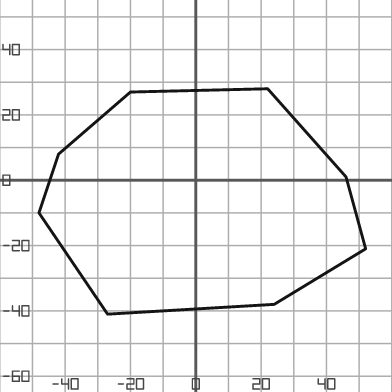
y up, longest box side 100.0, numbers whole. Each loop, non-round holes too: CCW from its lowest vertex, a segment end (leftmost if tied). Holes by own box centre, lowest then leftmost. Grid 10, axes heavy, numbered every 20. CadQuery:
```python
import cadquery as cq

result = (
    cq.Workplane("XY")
    .moveTo(-27.0, -41.0)
    .lineTo(24.0, -38.0)
    .lineTo(52.0, -21.0)
    .lineTo(46.0, 1.0)
    .lineTo(22.0, 28.0)
    .lineTo(-20.0, 27.0)
    .lineTo(-42.0, 8.0)
    .lineTo(-48.0, -10.0)
    .close()
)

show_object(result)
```